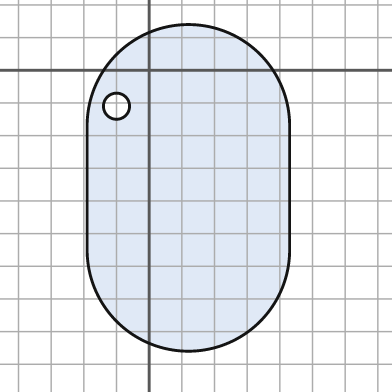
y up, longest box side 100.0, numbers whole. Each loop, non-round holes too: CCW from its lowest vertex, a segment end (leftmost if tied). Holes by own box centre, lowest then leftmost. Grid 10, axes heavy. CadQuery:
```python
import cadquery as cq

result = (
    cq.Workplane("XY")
    .moveTo(-19.0, -55.0)
    .threePointArc((12.0, -86.0), (43.0, -55.0))
    .lineTo(43.0, -17.0)
    .threePointArc((12.0, 14.0), (-19.0, -17.0))
    .close()
    .moveTo(-10.0, -11.0)
    .circle(4.0)
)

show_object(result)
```